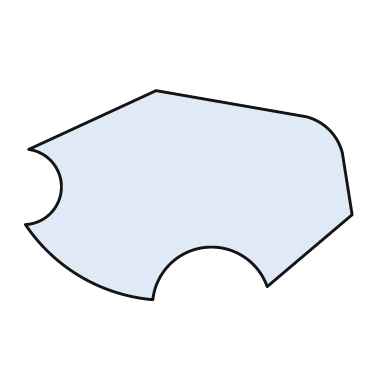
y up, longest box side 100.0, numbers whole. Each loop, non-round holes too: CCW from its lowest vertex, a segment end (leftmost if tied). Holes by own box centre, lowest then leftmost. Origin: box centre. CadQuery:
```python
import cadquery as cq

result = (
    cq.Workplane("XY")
    .moveTo(-11.0, -32.0)
    .threePointArc((5.0, -16.0), (24.0, -28.0))
    .lineTo(50.0, -6.0)
    .lineTo(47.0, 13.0)
    .threePointArc((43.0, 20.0), (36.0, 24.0))
    .lineTo(-10.0, 32.0)
    .lineTo(-49.0, 14.0)
    .threePointArc((-39.0, 2.0), (-50.0, -9.0))
    .threePointArc((-33.0, -25.0), (-11.0, -32.0))
    .close()
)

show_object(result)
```